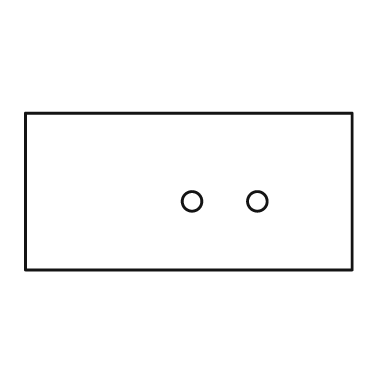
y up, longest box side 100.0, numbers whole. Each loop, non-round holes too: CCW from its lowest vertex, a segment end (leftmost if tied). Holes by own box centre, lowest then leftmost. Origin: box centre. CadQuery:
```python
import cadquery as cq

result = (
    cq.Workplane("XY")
    .moveTo(-50.0, -24.0)
    .lineTo(50.0, -24.0)
    .lineTo(50.0, 24.0)
    .lineTo(-50.0, 24.0)
    .close()
    .moveTo(1.0, -3.0)
    .circle(3.0)
    .moveTo(21.0, -3.0)
    .circle(3.0)
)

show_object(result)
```